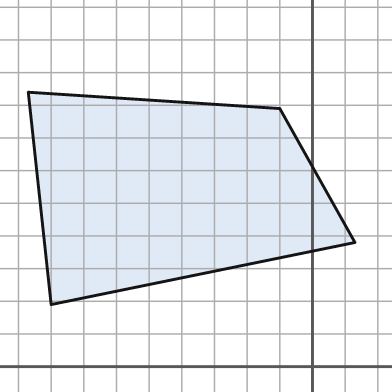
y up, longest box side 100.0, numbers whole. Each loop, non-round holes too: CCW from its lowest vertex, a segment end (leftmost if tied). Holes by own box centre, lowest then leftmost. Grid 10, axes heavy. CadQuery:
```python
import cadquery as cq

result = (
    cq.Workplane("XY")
    .moveTo(-80.0, 19.0)
    .lineTo(13.0, 38.0)
    .lineTo(-10.0, 79.0)
    .lineTo(-87.0, 84.0)
    .close()
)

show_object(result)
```